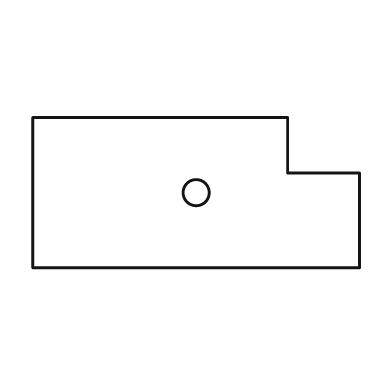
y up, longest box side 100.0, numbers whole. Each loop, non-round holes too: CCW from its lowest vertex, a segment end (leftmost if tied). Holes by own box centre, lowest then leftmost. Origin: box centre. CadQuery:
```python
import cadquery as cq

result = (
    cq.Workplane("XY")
    .moveTo(-50.0, -23.0)
    .lineTo(50.0, -23.0)
    .lineTo(50.0, 6.0)
    .lineTo(28.0, 6.0)
    .lineTo(28.0, 23.0)
    .lineTo(-50.0, 23.0)
    .close()
    .moveTo(0.0, 0.0)
    .circle(4.0)
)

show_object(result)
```